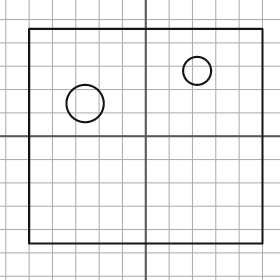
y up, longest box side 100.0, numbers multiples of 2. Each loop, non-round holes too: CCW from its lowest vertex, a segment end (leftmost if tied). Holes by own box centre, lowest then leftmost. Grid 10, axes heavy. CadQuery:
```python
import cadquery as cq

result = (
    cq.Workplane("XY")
    .moveTo(-50.0, -46.0)
    .lineTo(50.0, -46.0)
    .lineTo(50.0, 46.0)
    .lineTo(-50.0, 46.0)
    .close()
    .moveTo(-26.0, 14.0)
    .circle(8.0)
    .moveTo(22.0, 28.0)
    .circle(6.0)
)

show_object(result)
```